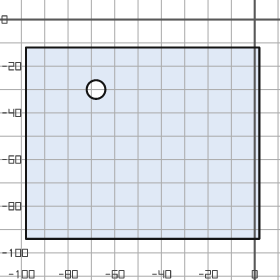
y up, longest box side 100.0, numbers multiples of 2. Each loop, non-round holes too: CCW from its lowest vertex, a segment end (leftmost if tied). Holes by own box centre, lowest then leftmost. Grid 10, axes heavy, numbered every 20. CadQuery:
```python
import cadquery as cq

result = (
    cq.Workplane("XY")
    .moveTo(-98.0, -94.0)
    .lineTo(2.0, -94.0)
    .lineTo(2.0, -12.0)
    .lineTo(-98.0, -12.0)
    .close()
    .moveTo(-68.0, -30.0)
    .circle(4.0)
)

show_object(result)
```